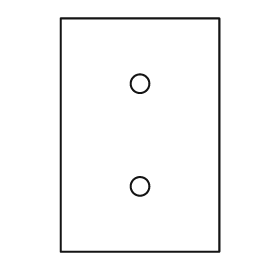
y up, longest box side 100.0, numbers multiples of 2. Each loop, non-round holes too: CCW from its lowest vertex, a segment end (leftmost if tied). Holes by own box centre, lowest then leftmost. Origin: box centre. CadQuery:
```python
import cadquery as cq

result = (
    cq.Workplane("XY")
    .moveTo(-34.0, -50.0)
    .lineTo(34.0, -50.0)
    .lineTo(34.0, 50.0)
    .lineTo(-34.0, 50.0)
    .close()
    .moveTo(0.0, -22.0)
    .circle(4.0)
    .moveTo(0.0, 22.0)
    .circle(4.0)
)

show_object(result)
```